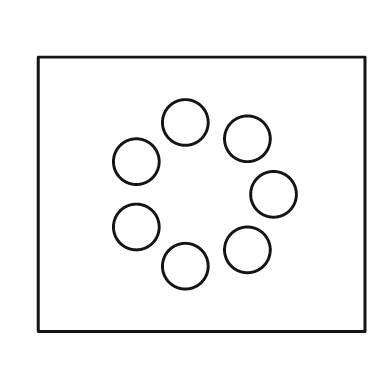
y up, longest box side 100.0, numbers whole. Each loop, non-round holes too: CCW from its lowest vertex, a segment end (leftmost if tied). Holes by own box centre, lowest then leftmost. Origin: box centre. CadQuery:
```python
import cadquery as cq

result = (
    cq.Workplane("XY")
    .moveTo(-50.0, -42.0)
    .lineTo(50.0, -42.0)
    .lineTo(50.0, 42.0)
    .lineTo(-50.0, 42.0)
    .close()
    .moveTo(-5.0, -22.0)
    .circle(7.0)
    .moveTo(14.0, -17.0)
    .circle(7.0)
    .moveTo(-20.0, -10.0)
    .circle(7.0)
    .moveTo(22.0, 0.0)
    .circle(7.0)
    .moveTo(-20.0, 10.0)
    .circle(7.0)
    .moveTo(14.0, 17.0)
    .circle(7.0)
    .moveTo(-5.0, 22.0)
    .circle(7.0)
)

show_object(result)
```